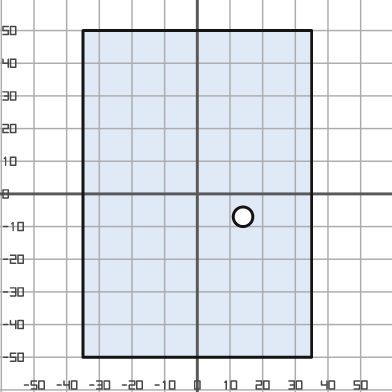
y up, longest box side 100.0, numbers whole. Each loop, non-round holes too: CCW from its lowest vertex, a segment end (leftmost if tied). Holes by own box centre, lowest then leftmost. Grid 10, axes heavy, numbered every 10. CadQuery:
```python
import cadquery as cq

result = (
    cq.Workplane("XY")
    .moveTo(-35.0, -50.0)
    .lineTo(35.0, -50.0)
    .lineTo(35.0, 50.0)
    .lineTo(-35.0, 50.0)
    .close()
    .moveTo(14.0, -7.0)
    .circle(3.0)
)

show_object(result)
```